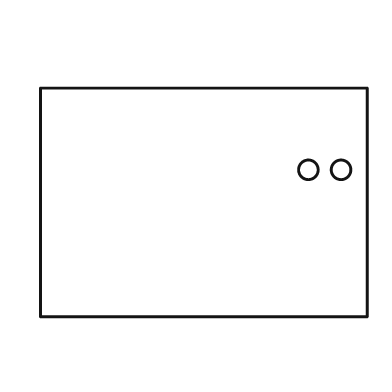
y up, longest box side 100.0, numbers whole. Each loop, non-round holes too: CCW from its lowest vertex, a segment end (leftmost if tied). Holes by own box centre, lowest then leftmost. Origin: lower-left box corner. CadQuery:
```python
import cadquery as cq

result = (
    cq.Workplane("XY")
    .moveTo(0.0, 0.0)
    .lineTo(100.0, 0.0)
    .lineTo(100.0, 70.0)
    .lineTo(0.0, 70.0)
    .close()
    .moveTo(82.0, 45.0)
    .circle(3.0)
    .moveTo(92.0, 45.0)
    .circle(3.0)
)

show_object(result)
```